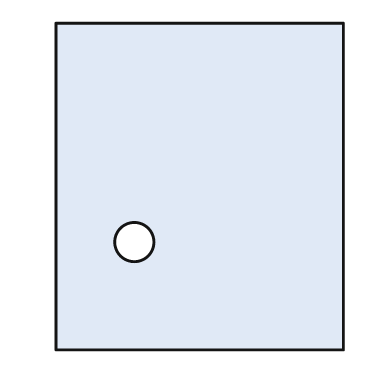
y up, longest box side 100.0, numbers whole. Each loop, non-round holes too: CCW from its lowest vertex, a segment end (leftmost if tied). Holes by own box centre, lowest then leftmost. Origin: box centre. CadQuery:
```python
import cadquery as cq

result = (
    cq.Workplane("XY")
    .moveTo(-44.0, -50.0)
    .lineTo(44.0, -50.0)
    .lineTo(44.0, 50.0)
    .lineTo(-44.0, 50.0)
    .close()
    .moveTo(-20.0, -17.0)
    .circle(6.0)
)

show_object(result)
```